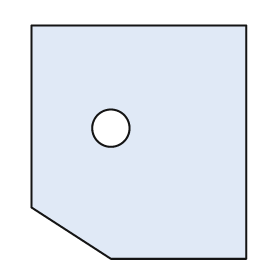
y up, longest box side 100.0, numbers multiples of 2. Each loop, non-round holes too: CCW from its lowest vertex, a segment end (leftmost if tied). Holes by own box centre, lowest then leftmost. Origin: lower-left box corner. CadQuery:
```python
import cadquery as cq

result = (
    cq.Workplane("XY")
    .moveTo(34.0, 0.0)
    .lineTo(92.0, 0.0)
    .lineTo(92.0, 100.0)
    .lineTo(0.0, 100.0)
    .lineTo(0.0, 22.0)
    .close()
    .moveTo(34.0, 56.0)
    .circle(8.0)
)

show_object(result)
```